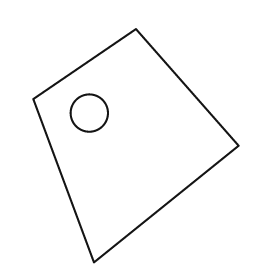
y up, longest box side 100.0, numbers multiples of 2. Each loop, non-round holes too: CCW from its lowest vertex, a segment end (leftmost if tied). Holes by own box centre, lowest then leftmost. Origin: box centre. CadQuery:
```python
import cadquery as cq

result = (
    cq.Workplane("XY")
    .moveTo(-18.0, -50.0)
    .lineTo(44.0, 0.0)
    .lineTo(0.0, 50.0)
    .lineTo(-44.0, 20.0)
    .close()
    .moveTo(-20.0, 14.0)
    .circle(8.0)
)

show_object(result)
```